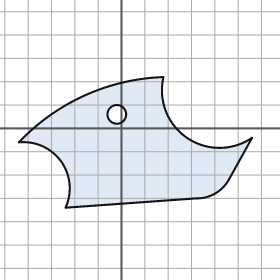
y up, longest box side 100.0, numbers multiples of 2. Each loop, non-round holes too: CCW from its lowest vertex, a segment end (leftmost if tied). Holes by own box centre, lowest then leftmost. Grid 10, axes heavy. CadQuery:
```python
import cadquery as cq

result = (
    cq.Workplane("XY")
    .moveTo(-24.0, -34.0)
    .lineTo(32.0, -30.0)
    .threePointArc((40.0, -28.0), (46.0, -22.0))
    .lineTo(56.0, -4.0)
    .threePointArc((28.0, -4.0), (18.0, 22.0))
    .threePointArc((-16.0, 14.0), (-44.0, -6.0))
    .threePointArc((-26.0, -14.0), (-24.0, -34.0))
    .close()
    .moveTo(-2.0, 6.0)
    .circle(4.0)
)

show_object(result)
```